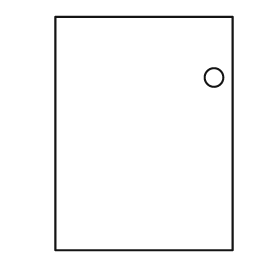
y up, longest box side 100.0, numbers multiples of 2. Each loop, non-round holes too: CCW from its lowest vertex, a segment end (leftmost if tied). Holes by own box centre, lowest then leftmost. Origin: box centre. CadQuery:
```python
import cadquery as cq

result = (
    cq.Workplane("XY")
    .moveTo(-38.0, -50.0)
    .lineTo(38.0, -50.0)
    .lineTo(38.0, 50.0)
    .lineTo(-38.0, 50.0)
    .close()
    .moveTo(30.0, 24.0)
    .circle(4.0)
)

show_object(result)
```